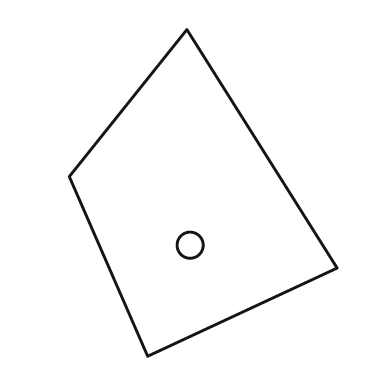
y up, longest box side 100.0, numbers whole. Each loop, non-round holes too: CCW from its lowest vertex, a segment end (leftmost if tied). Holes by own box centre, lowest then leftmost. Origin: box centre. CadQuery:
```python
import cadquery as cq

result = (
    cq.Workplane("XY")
    .moveTo(-17.0, -50.0)
    .lineTo(41.0, -23.0)
    .lineTo(-5.0, 50.0)
    .lineTo(-41.0, 5.0)
    .close()
    .moveTo(-4.0, -16.0)
    .circle(4.0)
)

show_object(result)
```